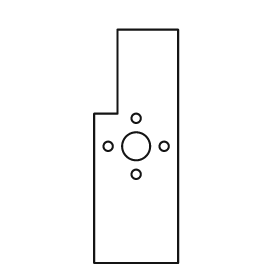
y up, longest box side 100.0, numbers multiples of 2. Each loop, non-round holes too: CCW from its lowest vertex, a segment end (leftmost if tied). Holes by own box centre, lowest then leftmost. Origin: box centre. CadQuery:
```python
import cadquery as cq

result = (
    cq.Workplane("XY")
    .moveTo(-18.0, -50.0)
    .lineTo(18.0, -50.0)
    .lineTo(18.0, 50.0)
    .lineTo(-8.0, 50.0)
    .lineTo(-8.0, 14.0)
    .lineTo(-18.0, 14.0)
    .close()
    .moveTo(0.0, -12.0)
    .circle(2.0)
    .moveTo(-12.0, 0.0)
    .circle(2.0)
    .moveTo(0.0, 0.0)
    .circle(6.0)
    .moveTo(12.0, 0.0)
    .circle(2.0)
    .moveTo(0.0, 12.0)
    .circle(2.0)
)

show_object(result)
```